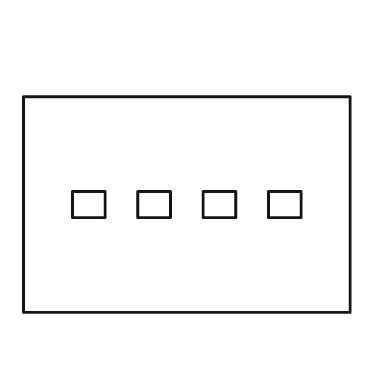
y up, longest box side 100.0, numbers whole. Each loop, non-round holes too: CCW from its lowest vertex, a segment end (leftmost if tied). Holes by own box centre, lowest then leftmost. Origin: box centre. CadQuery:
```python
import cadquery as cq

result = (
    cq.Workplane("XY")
    .moveTo(-50.0, -33.0)
    .lineTo(50.0, -33.0)
    .lineTo(50.0, 33.0)
    .lineTo(-50.0, 33.0)
    .close()
    .moveTo(-35.0, -4.0)
    .lineTo(-25.0, -4.0)
    .lineTo(-25.0, 4.0)
    .lineTo(-35.0, 4.0)
    .close()
    .moveTo(-15.0, -4.0)
    .lineTo(-5.0, -4.0)
    .lineTo(-5.0, 4.0)
    .lineTo(-15.0, 4.0)
    .close()
    .moveTo(5.0, -4.0)
    .lineTo(15.0, -4.0)
    .lineTo(15.0, 4.0)
    .lineTo(5.0, 4.0)
    .close()
    .moveTo(25.0, -4.0)
    .lineTo(35.0, -4.0)
    .lineTo(35.0, 4.0)
    .lineTo(25.0, 4.0)
    .close()
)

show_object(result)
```